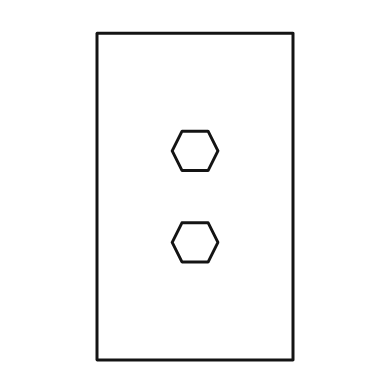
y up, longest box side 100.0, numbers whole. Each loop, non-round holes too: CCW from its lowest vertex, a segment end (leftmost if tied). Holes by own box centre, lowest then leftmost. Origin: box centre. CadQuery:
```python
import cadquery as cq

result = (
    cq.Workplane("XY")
    .moveTo(-30.0, -50.0)
    .lineTo(30.0, -50.0)
    .lineTo(30.0, 50.0)
    .lineTo(-30.0, 50.0)
    .close()
    .moveTo(-4.0, -20.0)
    .lineTo(4.0, -20.0)
    .lineTo(7.0, -14.0)
    .lineTo(4.0, -8.0)
    .lineTo(-4.0, -8.0)
    .lineTo(-7.0, -14.0)
    .close()
    .moveTo(-4.0, 8.0)
    .lineTo(4.0, 8.0)
    .lineTo(7.0, 14.0)
    .lineTo(4.0, 20.0)
    .lineTo(-4.0, 20.0)
    .lineTo(-7.0, 14.0)
    .close()
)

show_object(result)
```